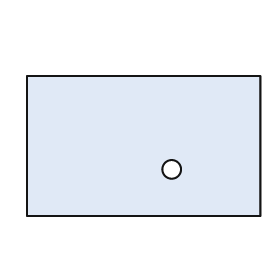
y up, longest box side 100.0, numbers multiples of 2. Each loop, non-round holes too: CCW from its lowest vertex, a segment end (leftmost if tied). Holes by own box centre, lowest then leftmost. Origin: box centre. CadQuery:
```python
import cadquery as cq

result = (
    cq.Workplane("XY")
    .moveTo(-50.0, -30.0)
    .lineTo(50.0, -30.0)
    .lineTo(50.0, 30.0)
    .lineTo(-50.0, 30.0)
    .close()
    .moveTo(12.0, -10.0)
    .circle(4.0)
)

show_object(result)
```